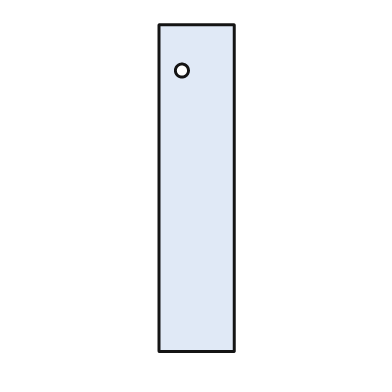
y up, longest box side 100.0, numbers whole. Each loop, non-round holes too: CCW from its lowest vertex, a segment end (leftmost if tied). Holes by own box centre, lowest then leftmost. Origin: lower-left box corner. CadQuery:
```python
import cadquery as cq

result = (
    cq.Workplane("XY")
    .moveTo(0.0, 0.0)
    .lineTo(23.0, 0.0)
    .lineTo(23.0, 100.0)
    .lineTo(0.0, 100.0)
    .close()
    .moveTo(7.0, 86.0)
    .circle(2.0)
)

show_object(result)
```